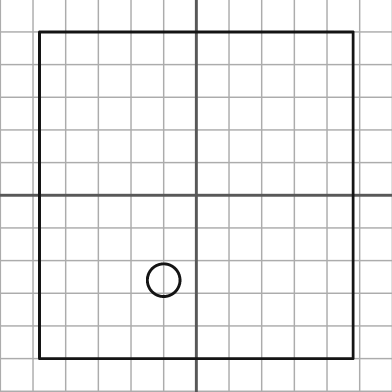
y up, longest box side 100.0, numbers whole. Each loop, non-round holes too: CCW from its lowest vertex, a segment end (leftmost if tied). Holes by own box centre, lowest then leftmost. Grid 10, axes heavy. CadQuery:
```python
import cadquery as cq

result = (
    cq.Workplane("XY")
    .moveTo(-48.0, -50.0)
    .lineTo(48.0, -50.0)
    .lineTo(48.0, 50.0)
    .lineTo(-48.0, 50.0)
    .close()
    .moveTo(-10.0, -26.0)
    .circle(5.0)
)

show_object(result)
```